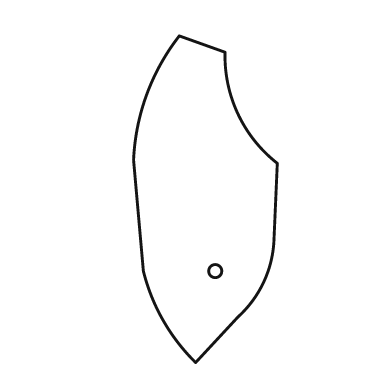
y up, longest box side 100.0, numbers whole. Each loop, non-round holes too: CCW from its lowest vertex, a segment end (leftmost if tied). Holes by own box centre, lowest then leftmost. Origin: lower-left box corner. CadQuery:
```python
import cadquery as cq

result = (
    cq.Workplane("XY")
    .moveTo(19.0, 0.0)
    .lineTo(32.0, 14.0)
    .threePointArc((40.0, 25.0), (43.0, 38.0))
    .lineTo(44.0, 61.0)
    .threePointArc((32.0, 76.0), (28.0, 95.0))
    .lineTo(14.0, 100.0)
    .threePointArc((4.0, 82.0), (0.0, 62.0))
    .lineTo(3.0, 28.0)
    .threePointArc((9.0, 13.0), (19.0, 0.0))
    .close()
    .moveTo(25.0, 28.0)
    .circle(2.0)
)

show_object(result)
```